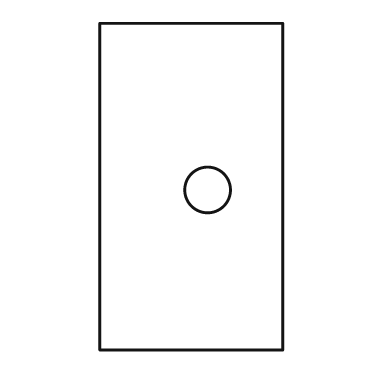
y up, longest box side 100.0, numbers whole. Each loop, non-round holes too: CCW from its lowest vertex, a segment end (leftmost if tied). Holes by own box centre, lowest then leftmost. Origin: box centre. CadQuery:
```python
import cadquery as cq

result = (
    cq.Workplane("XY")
    .moveTo(-28.0, -50.0)
    .lineTo(28.0, -50.0)
    .lineTo(28.0, 50.0)
    .lineTo(-28.0, 50.0)
    .close()
    .moveTo(5.0, -1.0)
    .circle(7.0)
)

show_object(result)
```